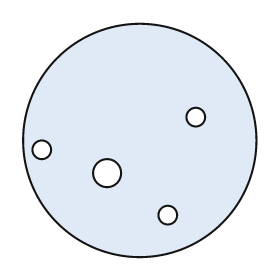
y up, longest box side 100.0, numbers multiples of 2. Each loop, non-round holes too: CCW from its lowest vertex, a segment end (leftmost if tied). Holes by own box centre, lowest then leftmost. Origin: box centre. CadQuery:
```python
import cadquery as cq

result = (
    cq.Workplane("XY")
    .moveTo(0.0, 0.0)
    .circle(50.0)
    .moveTo(12.0, -32.0)
    .circle(4.0)
    .moveTo(-14.0, -14.0)
    .circle(6.0)
    .moveTo(-42.0, -4.0)
    .circle(4.0)
    .moveTo(24.0, 10.0)
    .circle(4.0)
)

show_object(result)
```